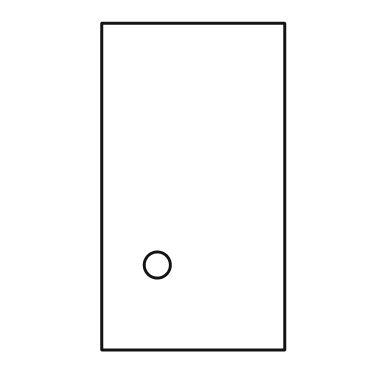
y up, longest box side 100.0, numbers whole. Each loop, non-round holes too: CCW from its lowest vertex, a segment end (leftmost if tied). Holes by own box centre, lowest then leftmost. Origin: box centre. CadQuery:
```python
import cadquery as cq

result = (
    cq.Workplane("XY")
    .moveTo(-28.0, -50.0)
    .lineTo(28.0, -50.0)
    .lineTo(28.0, 50.0)
    .lineTo(-28.0, 50.0)
    .close()
    .moveTo(-11.0, -24.0)
    .circle(4.0)
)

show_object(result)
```